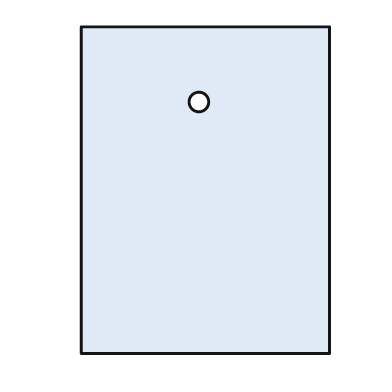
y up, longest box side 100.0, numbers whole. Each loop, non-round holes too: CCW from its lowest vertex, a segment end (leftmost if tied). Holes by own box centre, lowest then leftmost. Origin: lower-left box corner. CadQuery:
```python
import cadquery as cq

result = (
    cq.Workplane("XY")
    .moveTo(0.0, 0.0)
    .lineTo(76.0, 0.0)
    .lineTo(76.0, 100.0)
    .lineTo(0.0, 100.0)
    .close()
    .moveTo(36.0, 77.0)
    .circle(3.0)
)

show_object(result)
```